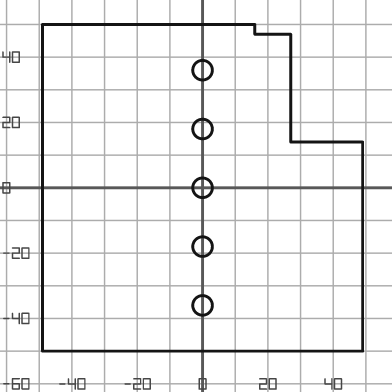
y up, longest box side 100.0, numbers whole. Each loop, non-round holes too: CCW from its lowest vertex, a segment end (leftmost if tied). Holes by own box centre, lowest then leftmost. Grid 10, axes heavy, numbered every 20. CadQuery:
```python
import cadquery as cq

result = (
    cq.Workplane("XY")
    .moveTo(-49.0, -50.0)
    .lineTo(49.0, -50.0)
    .lineTo(49.0, 14.0)
    .lineTo(27.0, 14.0)
    .lineTo(27.0, 47.0)
    .lineTo(16.0, 47.0)
    .lineTo(16.0, 50.0)
    .lineTo(-49.0, 50.0)
    .close()
    .moveTo(0.0, -36.0)
    .circle(3.0)
    .moveTo(0.0, -18.0)
    .circle(3.0)
    .moveTo(0.0, 0.0)
    .circle(3.0)
    .moveTo(0.0, 18.0)
    .circle(3.0)
    .moveTo(0.0, 36.0)
    .circle(3.0)
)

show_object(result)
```